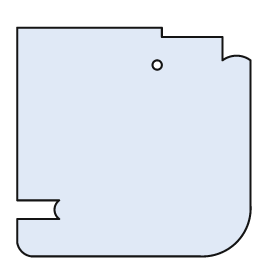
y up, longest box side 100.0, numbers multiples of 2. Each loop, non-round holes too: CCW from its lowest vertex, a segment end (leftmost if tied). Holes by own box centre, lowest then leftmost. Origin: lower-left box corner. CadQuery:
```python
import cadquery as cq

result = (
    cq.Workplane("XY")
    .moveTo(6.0, 0.0)
    .lineTo(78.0, 0.0)
    .threePointArc((94.0, 6.0), (100.0, 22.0))
    .lineTo(100.0, 84.0)
    .threePointArc((94.0, 86.0), (88.0, 84.0))
    .lineTo(88.0, 94.0)
    .lineTo(62.0, 94.0)
    .lineTo(62.0, 98.0)
    .lineTo(0.0, 98.0)
    .lineTo(0.0, 24.0)
    .lineTo(18.0, 24.0)
    .threePointArc((16.0, 20.0), (18.0, 16.0))
    .lineTo(0.0, 16.0)
    .lineTo(0.0, 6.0)
    .threePointArc((2.0, 2.0), (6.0, 0.0))
    .close()
    .moveTo(60.0, 82.0)
    .circle(2.0)
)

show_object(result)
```